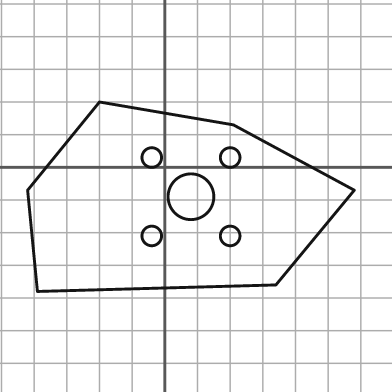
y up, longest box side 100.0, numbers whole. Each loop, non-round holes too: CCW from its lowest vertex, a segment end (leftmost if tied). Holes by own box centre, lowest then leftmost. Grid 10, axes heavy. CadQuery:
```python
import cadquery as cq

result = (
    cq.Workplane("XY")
    .moveTo(-39.0, -38.0)
    .lineTo(34.0, -36.0)
    .lineTo(58.0, -7.0)
    .lineTo(21.0, 13.0)
    .lineTo(-20.0, 20.0)
    .lineTo(-42.0, -7.0)
    .close()
    .moveTo(-4.0, -21.0)
    .circle(3.0)
    .moveTo(20.0, -21.0)
    .circle(3.0)
    .moveTo(8.0, -9.0)
    .circle(7.0)
    .moveTo(-4.0, 3.0)
    .circle(3.0)
    .moveTo(20.0, 3.0)
    .circle(3.0)
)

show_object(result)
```